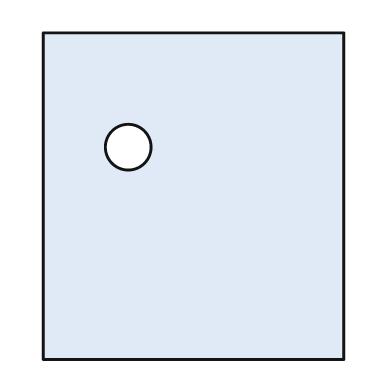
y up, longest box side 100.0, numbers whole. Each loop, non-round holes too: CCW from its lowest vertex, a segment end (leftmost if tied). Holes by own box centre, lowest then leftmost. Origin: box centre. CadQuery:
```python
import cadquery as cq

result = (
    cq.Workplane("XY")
    .moveTo(-46.0, -50.0)
    .lineTo(46.0, -50.0)
    .lineTo(46.0, 50.0)
    .lineTo(-46.0, 50.0)
    .close()
    .moveTo(-20.0, 15.0)
    .circle(7.0)
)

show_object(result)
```